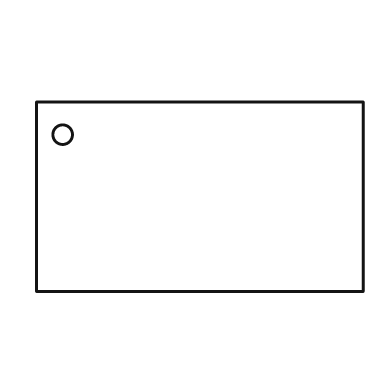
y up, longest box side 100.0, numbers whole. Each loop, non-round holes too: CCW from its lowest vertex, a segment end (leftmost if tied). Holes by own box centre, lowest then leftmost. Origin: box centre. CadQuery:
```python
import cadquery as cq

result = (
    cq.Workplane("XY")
    .moveTo(-50.0, -29.0)
    .lineTo(50.0, -29.0)
    .lineTo(50.0, 29.0)
    .lineTo(-50.0, 29.0)
    .close()
    .moveTo(-42.0, 19.0)
    .circle(3.0)
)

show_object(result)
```